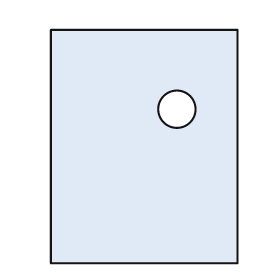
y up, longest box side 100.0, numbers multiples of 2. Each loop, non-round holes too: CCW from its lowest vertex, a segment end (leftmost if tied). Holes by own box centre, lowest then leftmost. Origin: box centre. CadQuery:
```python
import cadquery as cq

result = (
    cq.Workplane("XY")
    .moveTo(-40.0, -50.0)
    .lineTo(40.0, -50.0)
    .lineTo(40.0, 50.0)
    .lineTo(-40.0, 50.0)
    .close()
    .moveTo(14.0, 16.0)
    .circle(8.0)
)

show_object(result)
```